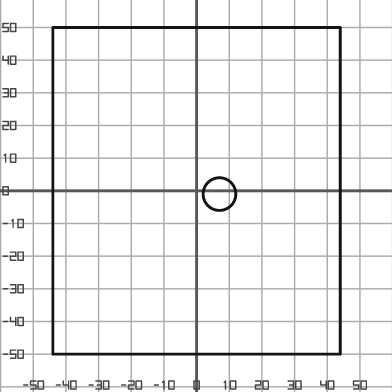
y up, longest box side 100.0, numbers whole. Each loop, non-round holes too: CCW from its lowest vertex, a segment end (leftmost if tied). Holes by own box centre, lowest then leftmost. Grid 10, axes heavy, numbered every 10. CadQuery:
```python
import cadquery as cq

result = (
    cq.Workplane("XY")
    .moveTo(-44.0, -50.0)
    .lineTo(44.0, -50.0)
    .lineTo(44.0, 50.0)
    .lineTo(-44.0, 50.0)
    .close()
    .moveTo(7.0, -1.0)
    .circle(5.0)
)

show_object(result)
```